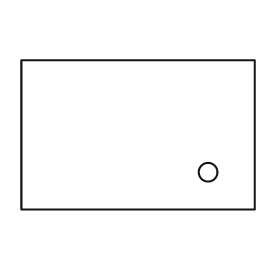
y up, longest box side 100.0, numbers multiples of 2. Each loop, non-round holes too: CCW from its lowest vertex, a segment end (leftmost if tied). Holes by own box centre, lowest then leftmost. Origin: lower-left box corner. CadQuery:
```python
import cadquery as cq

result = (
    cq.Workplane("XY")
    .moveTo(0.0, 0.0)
    .lineTo(100.0, 0.0)
    .lineTo(100.0, 64.0)
    .lineTo(0.0, 64.0)
    .close()
    .moveTo(80.0, 16.0)
    .circle(4.0)
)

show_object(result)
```